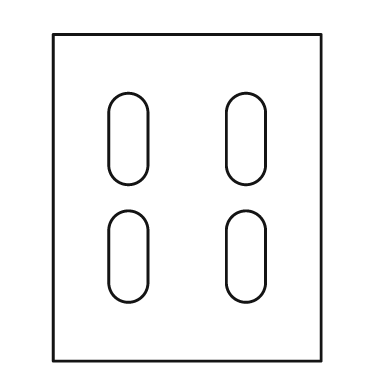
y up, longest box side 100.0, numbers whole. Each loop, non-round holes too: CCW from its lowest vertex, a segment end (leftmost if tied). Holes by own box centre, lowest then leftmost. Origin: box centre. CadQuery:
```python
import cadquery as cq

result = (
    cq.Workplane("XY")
    .moveTo(-41.0, -50.0)
    .lineTo(41.0, -50.0)
    .lineTo(41.0, 50.0)
    .lineTo(-41.0, 50.0)
    .close()
    .moveTo(-24.0, -26.0)
    .threePointArc((-18.0, -32.0), (-12.0, -26.0))
    .lineTo(-12.0, -10.0)
    .threePointArc((-18.0, -4.0), (-24.0, -10.0))
    .close()
    .moveTo(12.0, -26.0)
    .threePointArc((18.0, -32.0), (24.0, -26.0))
    .lineTo(24.0, -10.0)
    .threePointArc((18.0, -4.0), (12.0, -10.0))
    .close()
    .moveTo(-24.0, 10.0)
    .threePointArc((-18.0, 4.0), (-12.0, 10.0))
    .lineTo(-12.0, 26.0)
    .threePointArc((-18.0, 32.0), (-24.0, 26.0))
    .close()
    .moveTo(12.0, 10.0)
    .threePointArc((18.0, 4.0), (24.0, 10.0))
    .lineTo(24.0, 26.0)
    .threePointArc((18.0, 32.0), (12.0, 26.0))
    .close()
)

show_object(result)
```